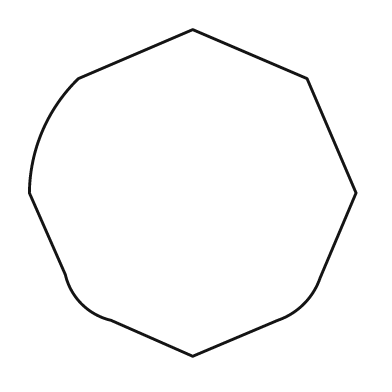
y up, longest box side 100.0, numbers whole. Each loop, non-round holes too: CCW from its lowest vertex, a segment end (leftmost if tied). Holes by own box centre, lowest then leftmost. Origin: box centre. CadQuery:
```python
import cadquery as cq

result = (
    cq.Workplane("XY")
    .moveTo(0.0, -50.0)
    .lineTo(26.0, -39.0)
    .threePointArc((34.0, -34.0), (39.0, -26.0))
    .lineTo(50.0, 0.0)
    .lineTo(35.0, 35.0)
    .lineTo(0.0, 50.0)
    .lineTo(-35.0, 35.0)
    .threePointArc((-46.0, 19.0), (-50.0, 0.0))
    .lineTo(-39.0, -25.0)
    .threePointArc((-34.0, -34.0), (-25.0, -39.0))
    .close()
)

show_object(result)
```